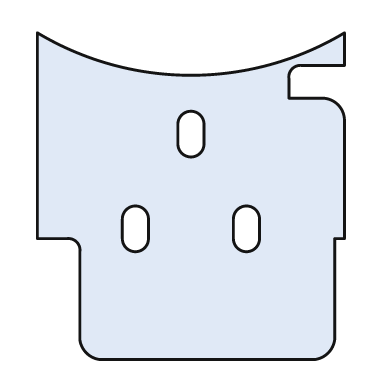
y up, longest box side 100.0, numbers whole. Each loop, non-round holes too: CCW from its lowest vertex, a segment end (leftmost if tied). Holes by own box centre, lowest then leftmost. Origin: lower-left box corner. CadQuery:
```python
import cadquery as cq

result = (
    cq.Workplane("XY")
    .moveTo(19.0, 0.0)
    .lineTo(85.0, 0.0)
    .threePointArc((89.0, 2.0), (91.0, 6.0))
    .lineTo(91.0, 37.0)
    .lineTo(94.0, 37.0)
    .lineTo(94.0, 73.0)
    .threePointArc((92.0, 78.0), (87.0, 80.0))
    .lineTo(77.0, 80.0)
    .lineTo(77.0, 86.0)
    .threePointArc((78.0, 89.0), (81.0, 90.0))
    .lineTo(94.0, 90.0)
    .lineTo(94.0, 100.0)
    .threePointArc((47.0, 87.0), (0.0, 100.0))
    .lineTo(0.0, 37.0)
    .lineTo(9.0, 37.0)
    .threePointArc((12.0, 36.0), (13.0, 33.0))
    .lineTo(13.0, 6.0)
    .threePointArc((15.0, 2.0), (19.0, 0.0))
    .close()
    .moveTo(26.0, 37.0)
    .threePointArc((30.0, 33.0), (34.0, 37.0))
    .lineTo(34.0, 43.0)
    .threePointArc((30.0, 47.0), (26.0, 43.0))
    .close()
    .moveTo(60.0, 37.0)
    .threePointArc((64.0, 33.0), (68.0, 37.0))
    .lineTo(68.0, 43.0)
    .threePointArc((64.0, 47.0), (60.0, 43.0))
    .close()
    .moveTo(43.0, 66.0)
    .threePointArc((47.0, 62.0), (51.0, 66.0))
    .lineTo(51.0, 72.0)
    .threePointArc((47.0, 76.0), (43.0, 72.0))
    .close()
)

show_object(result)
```